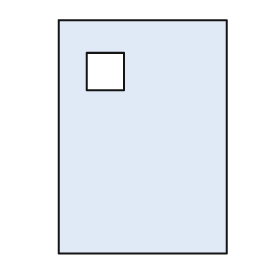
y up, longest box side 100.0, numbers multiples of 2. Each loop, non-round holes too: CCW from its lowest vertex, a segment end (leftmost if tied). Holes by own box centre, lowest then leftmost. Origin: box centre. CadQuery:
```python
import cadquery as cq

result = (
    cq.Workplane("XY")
    .moveTo(-36.0, -50.0)
    .lineTo(36.0, -50.0)
    .lineTo(36.0, 50.0)
    .lineTo(-36.0, 50.0)
    .close()
    .moveTo(-24.0, 20.0)
    .lineTo(-8.0, 20.0)
    .lineTo(-8.0, 36.0)
    .lineTo(-24.0, 36.0)
    .close()
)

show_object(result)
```